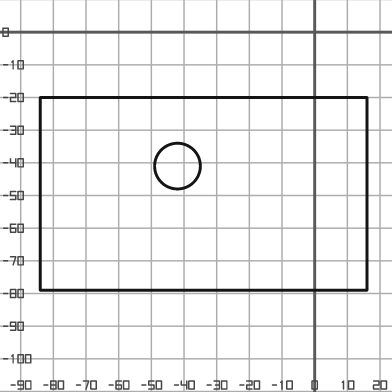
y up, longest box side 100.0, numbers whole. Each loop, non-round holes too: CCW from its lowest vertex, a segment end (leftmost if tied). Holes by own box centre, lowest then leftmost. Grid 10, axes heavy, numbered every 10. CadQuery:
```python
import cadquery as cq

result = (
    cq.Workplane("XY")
    .moveTo(-84.0, -79.0)
    .lineTo(16.0, -79.0)
    .lineTo(16.0, -20.0)
    .lineTo(-84.0, -20.0)
    .close()
    .moveTo(-42.0, -41.0)
    .circle(7.0)
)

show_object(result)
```